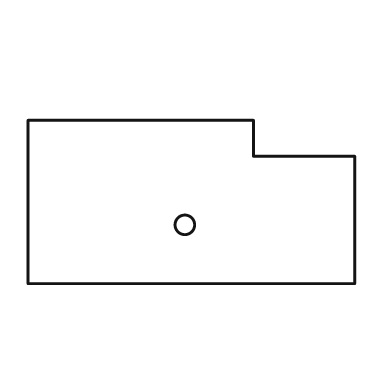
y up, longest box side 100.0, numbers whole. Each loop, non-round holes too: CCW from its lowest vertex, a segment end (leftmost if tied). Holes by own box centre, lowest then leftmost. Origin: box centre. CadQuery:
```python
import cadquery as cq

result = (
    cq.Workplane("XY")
    .moveTo(-50.0, -25.0)
    .lineTo(50.0, -25.0)
    .lineTo(50.0, 14.0)
    .lineTo(19.0, 14.0)
    .lineTo(19.0, 25.0)
    .lineTo(-50.0, 25.0)
    .close()
    .moveTo(-2.0, -7.0)
    .circle(3.0)
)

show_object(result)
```